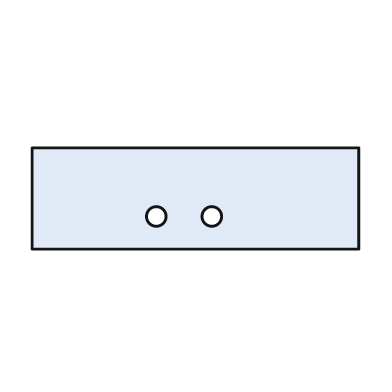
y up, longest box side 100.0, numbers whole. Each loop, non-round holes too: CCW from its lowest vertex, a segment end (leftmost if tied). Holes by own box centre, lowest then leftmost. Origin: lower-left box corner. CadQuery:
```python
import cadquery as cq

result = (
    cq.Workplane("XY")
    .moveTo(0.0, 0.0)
    .lineTo(100.0, 0.0)
    .lineTo(100.0, 31.0)
    .lineTo(0.0, 31.0)
    .close()
    .moveTo(38.0, 10.0)
    .circle(3.0)
    .moveTo(55.0, 10.0)
    .circle(3.0)
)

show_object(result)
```